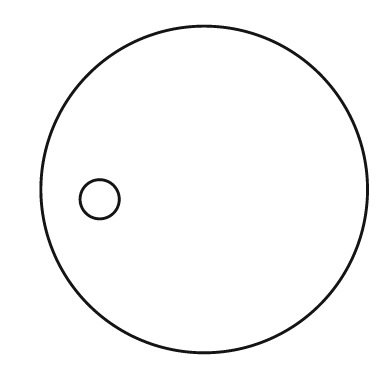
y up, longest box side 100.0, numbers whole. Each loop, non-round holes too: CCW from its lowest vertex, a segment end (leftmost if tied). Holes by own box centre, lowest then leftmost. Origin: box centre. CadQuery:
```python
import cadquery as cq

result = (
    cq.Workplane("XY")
    .moveTo(0.0, 0.0)
    .circle(50.0)
    .moveTo(-32.0, -3.0)
    .circle(6.0)
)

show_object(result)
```